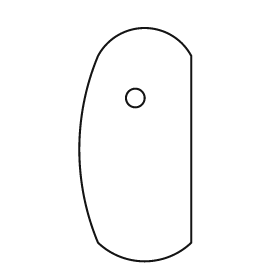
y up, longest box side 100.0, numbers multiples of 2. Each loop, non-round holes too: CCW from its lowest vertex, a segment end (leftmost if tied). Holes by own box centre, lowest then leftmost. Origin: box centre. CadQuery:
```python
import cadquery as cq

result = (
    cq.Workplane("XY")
    .moveTo(-16.0, -42.0)
    .threePointArc((4.0, -50.0), (24.0, -42.0))
    .lineTo(24.0, 38.0)
    .threePointArc((4.0, 50.0), (-16.0, 38.0))
    .threePointArc((-24.0, -2.0), (-16.0, -42.0))
    .close()
    .moveTo(0.0, 20.0)
    .circle(4.0)
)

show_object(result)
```